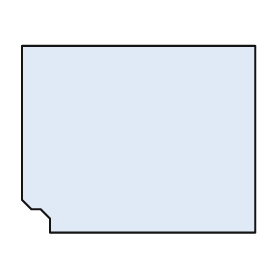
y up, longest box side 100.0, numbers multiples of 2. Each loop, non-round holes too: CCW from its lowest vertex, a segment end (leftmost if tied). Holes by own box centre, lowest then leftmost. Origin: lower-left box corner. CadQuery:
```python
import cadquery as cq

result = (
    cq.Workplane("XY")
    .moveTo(12.0, 0.0)
    .lineTo(100.0, 0.0)
    .lineTo(100.0, 80.0)
    .lineTo(0.0, 80.0)
    .lineTo(0.0, 14.0)
    .lineTo(4.0, 10.0)
    .lineTo(8.0, 10.0)
    .lineTo(12.0, 6.0)
    .close()
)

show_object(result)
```